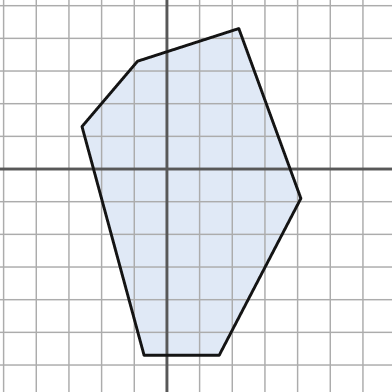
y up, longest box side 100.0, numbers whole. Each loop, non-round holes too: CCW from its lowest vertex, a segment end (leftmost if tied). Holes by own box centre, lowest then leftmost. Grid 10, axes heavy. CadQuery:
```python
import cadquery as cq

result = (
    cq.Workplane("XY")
    .moveTo(-7.0, -57.0)
    .lineTo(16.0, -57.0)
    .lineTo(41.0, -9.0)
    .lineTo(22.0, 43.0)
    .lineTo(-9.0, 33.0)
    .lineTo(-26.0, 13.0)
    .close()
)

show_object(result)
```